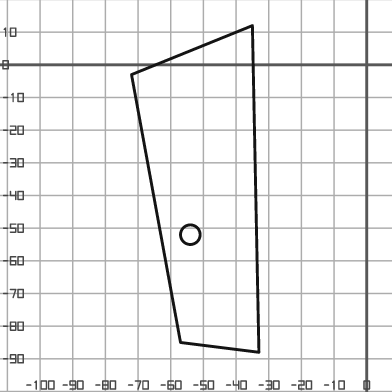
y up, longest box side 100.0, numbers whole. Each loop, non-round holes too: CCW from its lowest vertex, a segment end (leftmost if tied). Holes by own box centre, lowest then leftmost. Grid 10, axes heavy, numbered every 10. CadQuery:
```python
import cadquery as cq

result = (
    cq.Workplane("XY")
    .moveTo(-33.0, -88.0)
    .lineTo(-35.0, 12.0)
    .lineTo(-72.0, -3.0)
    .lineTo(-57.0, -85.0)
    .close()
    .moveTo(-54.0, -52.0)
    .circle(3.0)
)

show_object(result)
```